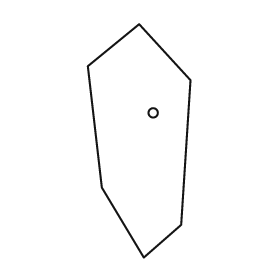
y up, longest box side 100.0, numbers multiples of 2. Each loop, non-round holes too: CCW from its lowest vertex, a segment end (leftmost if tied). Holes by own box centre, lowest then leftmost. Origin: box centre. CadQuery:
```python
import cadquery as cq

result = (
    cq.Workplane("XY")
    .moveTo(2.0, -50.0)
    .lineTo(18.0, -36.0)
    .lineTo(22.0, 26.0)
    .lineTo(0.0, 50.0)
    .lineTo(-22.0, 32.0)
    .lineTo(-16.0, -20.0)
    .close()
    .moveTo(6.0, 12.0)
    .circle(2.0)
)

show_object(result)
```